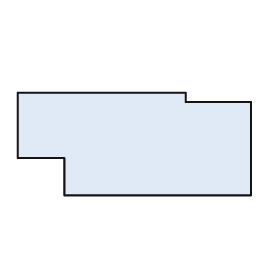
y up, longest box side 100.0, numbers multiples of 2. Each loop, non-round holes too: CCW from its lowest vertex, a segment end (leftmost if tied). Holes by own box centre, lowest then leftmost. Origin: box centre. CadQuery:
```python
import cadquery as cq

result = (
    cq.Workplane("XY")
    .moveTo(-30.0, -22.0)
    .lineTo(50.0, -22.0)
    .lineTo(50.0, 18.0)
    .lineTo(22.0, 18.0)
    .lineTo(22.0, 22.0)
    .lineTo(-50.0, 22.0)
    .lineTo(-50.0, -6.0)
    .lineTo(-30.0, -6.0)
    .close()
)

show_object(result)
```